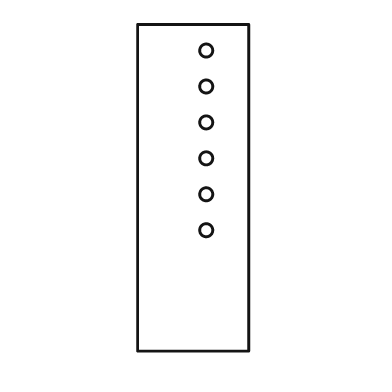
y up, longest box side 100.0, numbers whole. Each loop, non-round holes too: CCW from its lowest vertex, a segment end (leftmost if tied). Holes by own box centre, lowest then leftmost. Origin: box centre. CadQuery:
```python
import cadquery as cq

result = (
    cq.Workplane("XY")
    .moveTo(-17.0, -50.0)
    .lineTo(17.0, -50.0)
    .lineTo(17.0, 50.0)
    .lineTo(-17.0, 50.0)
    .close()
    .moveTo(4.0, -13.0)
    .circle(2.0)
    .moveTo(4.0, -2.0)
    .circle(2.0)
    .moveTo(4.0, 9.0)
    .circle(2.0)
    .moveTo(4.0, 20.0)
    .circle(2.0)
    .moveTo(4.0, 31.0)
    .circle(2.0)
    .moveTo(4.0, 42.0)
    .circle(2.0)
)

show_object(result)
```